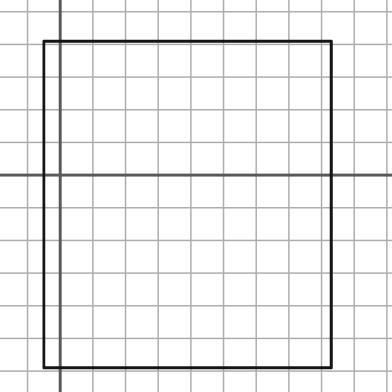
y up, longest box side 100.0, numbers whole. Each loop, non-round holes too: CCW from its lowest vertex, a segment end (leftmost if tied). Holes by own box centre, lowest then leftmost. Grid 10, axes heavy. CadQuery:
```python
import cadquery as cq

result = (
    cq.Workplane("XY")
    .moveTo(-5.0, -59.0)
    .lineTo(83.0, -59.0)
    .lineTo(83.0, 41.0)
    .lineTo(-5.0, 41.0)
    .close()
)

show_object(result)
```